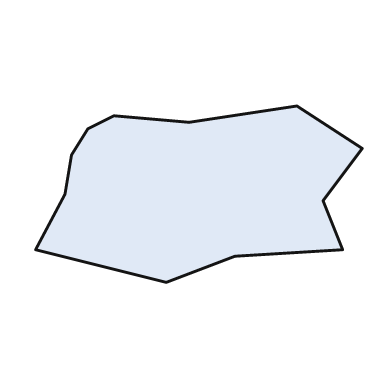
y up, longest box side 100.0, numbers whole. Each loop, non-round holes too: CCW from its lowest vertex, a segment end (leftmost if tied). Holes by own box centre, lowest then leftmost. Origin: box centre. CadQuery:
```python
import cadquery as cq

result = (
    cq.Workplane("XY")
    .moveTo(-10.0, -27.0)
    .lineTo(11.0, -19.0)
    .lineTo(44.0, -17.0)
    .lineTo(38.0, -2.0)
    .lineTo(50.0, 14.0)
    .lineTo(30.0, 27.0)
    .lineTo(-3.0, 22.0)
    .lineTo(-26.0, 24.0)
    .lineTo(-34.0, 20.0)
    .lineTo(-39.0, 12.0)
    .lineTo(-41.0, 0.0)
    .lineTo(-50.0, -17.0)
    .close()
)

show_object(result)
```